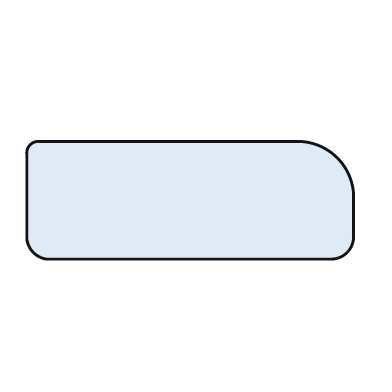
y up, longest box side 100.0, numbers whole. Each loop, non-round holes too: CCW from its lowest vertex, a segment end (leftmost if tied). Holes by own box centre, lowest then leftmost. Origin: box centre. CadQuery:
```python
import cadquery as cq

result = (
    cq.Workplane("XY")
    .moveTo(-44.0, -18.0)
    .lineTo(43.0, -18.0)
    .threePointArc((48.0, -16.0), (50.0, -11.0))
    .lineTo(50.0, 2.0)
    .threePointArc((45.0, 13.0), (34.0, 18.0))
    .lineTo(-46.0, 18.0)
    .threePointArc((-49.0, 17.0), (-50.0, 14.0))
    .lineTo(-50.0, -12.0)
    .threePointArc((-48.0, -16.0), (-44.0, -18.0))
    .close()
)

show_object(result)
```